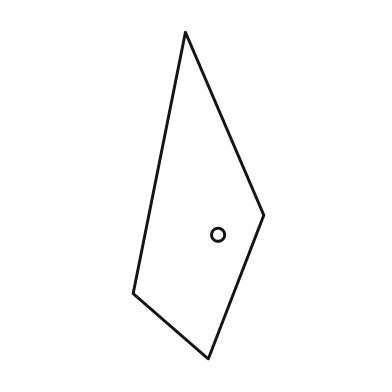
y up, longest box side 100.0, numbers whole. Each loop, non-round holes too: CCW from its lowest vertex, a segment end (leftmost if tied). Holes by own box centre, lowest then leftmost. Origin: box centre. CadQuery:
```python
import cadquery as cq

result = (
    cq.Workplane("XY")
    .moveTo(3.0, -50.0)
    .lineTo(20.0, -6.0)
    .lineTo(-4.0, 50.0)
    .lineTo(-20.0, -30.0)
    .close()
    .moveTo(6.0, -12.0)
    .circle(2.0)
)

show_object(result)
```